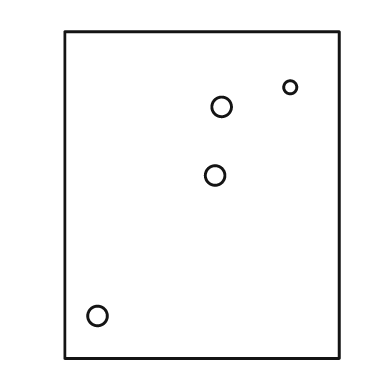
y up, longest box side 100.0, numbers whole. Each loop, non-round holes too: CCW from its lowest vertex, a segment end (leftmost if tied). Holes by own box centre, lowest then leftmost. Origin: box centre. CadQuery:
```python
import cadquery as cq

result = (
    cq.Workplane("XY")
    .moveTo(-42.0, -50.0)
    .lineTo(42.0, -50.0)
    .lineTo(42.0, 50.0)
    .lineTo(-42.0, 50.0)
    .close()
    .moveTo(-32.0, -37.0)
    .circle(3.0)
    .moveTo(4.0, 6.0)
    .circle(3.0)
    .moveTo(6.0, 27.0)
    .circle(3.0)
    .moveTo(27.0, 33.0)
    .circle(2.0)
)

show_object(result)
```